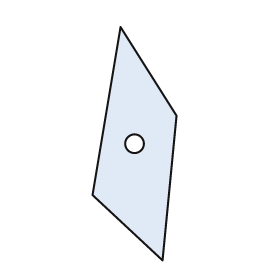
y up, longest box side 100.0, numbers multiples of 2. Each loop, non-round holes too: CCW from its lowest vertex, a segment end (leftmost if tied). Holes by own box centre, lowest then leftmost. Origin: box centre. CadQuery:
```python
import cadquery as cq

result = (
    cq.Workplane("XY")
    .moveTo(12.0, -50.0)
    .lineTo(18.0, 12.0)
    .lineTo(-6.0, 50.0)
    .lineTo(-18.0, -22.0)
    .close()
    .moveTo(0.0, 0.0)
    .circle(4.0)
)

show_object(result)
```